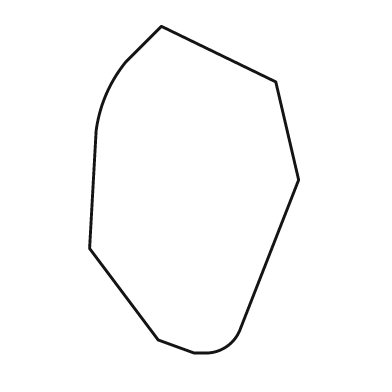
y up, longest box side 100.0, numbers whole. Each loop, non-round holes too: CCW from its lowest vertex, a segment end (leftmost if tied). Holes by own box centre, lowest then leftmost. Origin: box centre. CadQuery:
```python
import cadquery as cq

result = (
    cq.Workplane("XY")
    .moveTo(0.0, -50.0)
    .lineTo(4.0, -50.0)
    .threePointArc((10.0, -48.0), (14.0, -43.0))
    .lineTo(32.0, 3.0)
    .lineTo(25.0, 33.0)
    .lineTo(-10.0, 50.0)
    .lineTo(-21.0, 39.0)
    .threePointArc((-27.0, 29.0), (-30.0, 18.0))
    .lineTo(-32.0, -18.0)
    .lineTo(-11.0, -46.0)
    .close()
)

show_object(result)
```